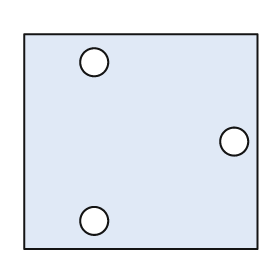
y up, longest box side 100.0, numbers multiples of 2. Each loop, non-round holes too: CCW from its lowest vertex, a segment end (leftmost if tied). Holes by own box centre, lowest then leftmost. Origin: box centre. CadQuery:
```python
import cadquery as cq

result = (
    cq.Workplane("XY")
    .moveTo(-50.0, -46.0)
    .lineTo(50.0, -46.0)
    .lineTo(50.0, 46.0)
    .lineTo(-50.0, 46.0)
    .close()
    .moveTo(-20.0, -34.0)
    .circle(6.0)
    .moveTo(40.0, 0.0)
    .circle(6.0)
    .moveTo(-20.0, 34.0)
    .circle(6.0)
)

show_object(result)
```